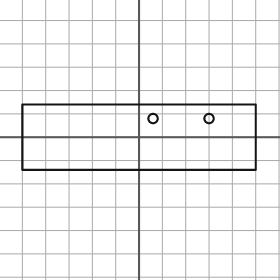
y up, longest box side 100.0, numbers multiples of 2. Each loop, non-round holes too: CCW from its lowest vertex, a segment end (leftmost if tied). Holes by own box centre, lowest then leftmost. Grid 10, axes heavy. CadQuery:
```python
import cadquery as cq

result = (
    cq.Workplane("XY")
    .moveTo(-50.0, -14.0)
    .lineTo(50.0, -14.0)
    .lineTo(50.0, 14.0)
    .lineTo(-50.0, 14.0)
    .close()
    .moveTo(6.0, 8.0)
    .circle(2.0)
    .moveTo(30.0, 8.0)
    .circle(2.0)
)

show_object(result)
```